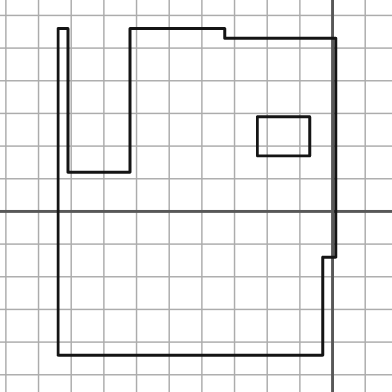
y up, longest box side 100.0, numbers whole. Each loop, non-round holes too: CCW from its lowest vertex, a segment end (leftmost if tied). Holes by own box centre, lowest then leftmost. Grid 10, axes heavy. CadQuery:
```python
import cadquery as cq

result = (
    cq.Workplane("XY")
    .moveTo(-84.0, -44.0)
    .lineTo(-3.0, -44.0)
    .lineTo(-3.0, -14.0)
    .lineTo(1.0, -14.0)
    .lineTo(1.0, 53.0)
    .lineTo(-33.0, 53.0)
    .lineTo(-33.0, 56.0)
    .lineTo(-62.0, 56.0)
    .lineTo(-62.0, 12.0)
    .lineTo(-81.0, 12.0)
    .lineTo(-81.0, 56.0)
    .lineTo(-84.0, 56.0)
    .close()
    .moveTo(-23.0, 17.0)
    .lineTo(-7.0, 17.0)
    .lineTo(-7.0, 29.0)
    .lineTo(-23.0, 29.0)
    .close()
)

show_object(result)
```